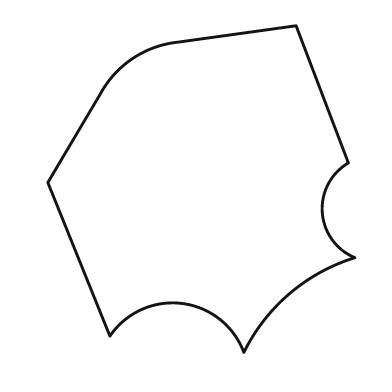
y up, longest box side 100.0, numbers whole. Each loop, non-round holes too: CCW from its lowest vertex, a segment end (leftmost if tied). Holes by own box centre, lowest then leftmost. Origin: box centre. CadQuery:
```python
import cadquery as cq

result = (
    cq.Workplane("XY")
    .moveTo(13.0, -50.0)
    .threePointArc((27.0, -32.0), (47.0, -21.0))
    .threePointArc((37.0, -7.0), (45.0, 8.0))
    .lineTo(29.0, 50.0)
    .lineTo(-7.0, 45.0)
    .threePointArc((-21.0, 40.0), (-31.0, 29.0))
    .lineTo(-47.0, 2.0)
    .lineTo(-28.0, -45.0)
    .threePointArc((-6.0, -35.0), (13.0, -50.0))
    .close()
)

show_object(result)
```